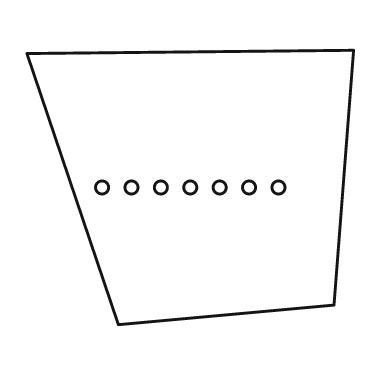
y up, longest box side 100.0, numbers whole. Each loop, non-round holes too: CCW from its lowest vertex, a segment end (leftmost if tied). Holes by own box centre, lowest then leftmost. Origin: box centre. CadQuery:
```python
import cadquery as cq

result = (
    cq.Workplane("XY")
    .moveTo(-22.0, -42.0)
    .lineTo(44.0, -36.0)
    .lineTo(50.0, 42.0)
    .lineTo(-50.0, 41.0)
    .close()
    .moveTo(-27.0, 0.0)
    .circle(2.0)
    .moveTo(-18.0, 0.0)
    .circle(2.0)
    .moveTo(-9.0, 0.0)
    .circle(2.0)
    .moveTo(0.0, 0.0)
    .circle(2.0)
    .moveTo(9.0, 0.0)
    .circle(2.0)
    .moveTo(18.0, 0.0)
    .circle(2.0)
    .moveTo(27.0, 0.0)
    .circle(2.0)
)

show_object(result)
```